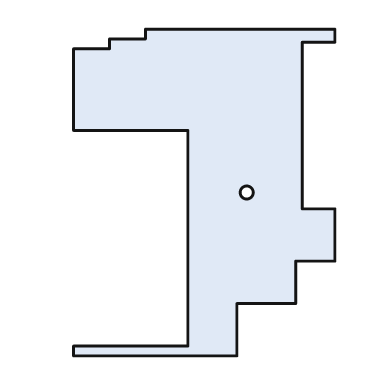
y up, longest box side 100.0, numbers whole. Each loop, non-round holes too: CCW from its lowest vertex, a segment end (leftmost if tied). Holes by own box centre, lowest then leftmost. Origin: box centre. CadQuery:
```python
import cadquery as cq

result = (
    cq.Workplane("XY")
    .moveTo(-40.0, -50.0)
    .lineTo(10.0, -50.0)
    .lineTo(10.0, -34.0)
    .lineTo(28.0, -34.0)
    .lineTo(28.0, -21.0)
    .lineTo(40.0, -21.0)
    .lineTo(40.0, -5.0)
    .lineTo(30.0, -5.0)
    .lineTo(30.0, 46.0)
    .lineTo(40.0, 46.0)
    .lineTo(40.0, 50.0)
    .lineTo(-18.0, 50.0)
    .lineTo(-18.0, 47.0)
    .lineTo(-29.0, 47.0)
    .lineTo(-29.0, 44.0)
    .lineTo(-40.0, 44.0)
    .lineTo(-40.0, 19.0)
    .lineTo(-5.0, 19.0)
    .lineTo(-5.0, -47.0)
    .lineTo(-40.0, -47.0)
    .close()
    .moveTo(13.0, 0.0)
    .circle(2.0)
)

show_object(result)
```